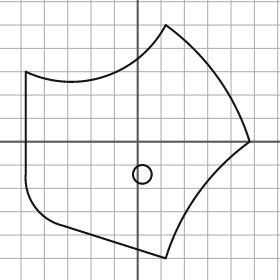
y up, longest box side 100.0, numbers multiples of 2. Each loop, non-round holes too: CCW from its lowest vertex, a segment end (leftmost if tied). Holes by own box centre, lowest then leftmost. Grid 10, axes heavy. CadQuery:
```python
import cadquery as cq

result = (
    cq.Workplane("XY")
    .moveTo(12.0, -50.0)
    .threePointArc((26.0, -22.0), (48.0, 0.0))
    .threePointArc((34.0, 28.0), (12.0, 50.0))
    .threePointArc((-14.0, 28.0), (-48.0, 30.0))
    .lineTo(-48.0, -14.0)
    .threePointArc((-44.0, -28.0), (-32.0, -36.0))
    .close()
    .moveTo(2.0, -14.0)
    .circle(4.0)
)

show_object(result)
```